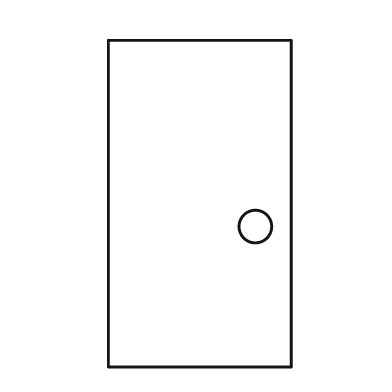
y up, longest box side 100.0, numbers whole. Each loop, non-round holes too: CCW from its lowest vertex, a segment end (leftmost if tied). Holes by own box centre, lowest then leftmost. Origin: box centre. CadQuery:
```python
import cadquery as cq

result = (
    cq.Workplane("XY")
    .moveTo(-28.0, -50.0)
    .lineTo(28.0, -50.0)
    .lineTo(28.0, 50.0)
    .lineTo(-28.0, 50.0)
    .close()
    .moveTo(17.0, -7.0)
    .circle(5.0)
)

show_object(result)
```